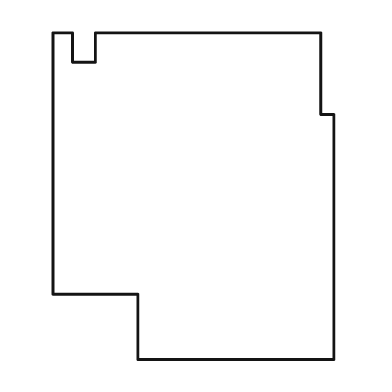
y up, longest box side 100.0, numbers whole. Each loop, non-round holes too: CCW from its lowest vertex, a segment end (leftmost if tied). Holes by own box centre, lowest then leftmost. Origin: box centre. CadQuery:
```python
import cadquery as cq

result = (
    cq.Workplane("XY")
    .moveTo(-17.0, -50.0)
    .lineTo(43.0, -50.0)
    .lineTo(43.0, 25.0)
    .lineTo(39.0, 25.0)
    .lineTo(39.0, 50.0)
    .lineTo(-30.0, 50.0)
    .lineTo(-30.0, 41.0)
    .lineTo(-37.0, 41.0)
    .lineTo(-37.0, 50.0)
    .lineTo(-43.0, 50.0)
    .lineTo(-43.0, -30.0)
    .lineTo(-17.0, -30.0)
    .close()
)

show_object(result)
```